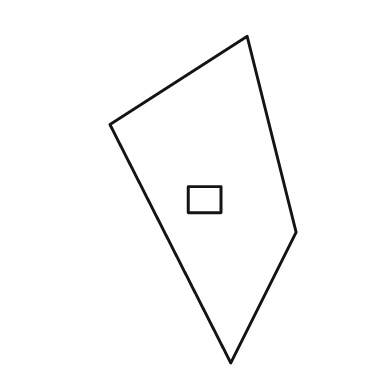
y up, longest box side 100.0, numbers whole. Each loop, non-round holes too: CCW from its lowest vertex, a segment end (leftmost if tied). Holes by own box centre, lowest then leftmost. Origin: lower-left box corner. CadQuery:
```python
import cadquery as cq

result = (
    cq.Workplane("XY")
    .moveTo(37.0, 0.0)
    .lineTo(57.0, 40.0)
    .lineTo(42.0, 100.0)
    .lineTo(0.0, 73.0)
    .close()
    .moveTo(24.0, 46.0)
    .lineTo(34.0, 46.0)
    .lineTo(34.0, 54.0)
    .lineTo(24.0, 54.0)
    .close()
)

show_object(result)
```